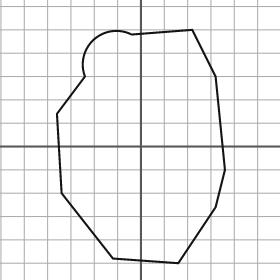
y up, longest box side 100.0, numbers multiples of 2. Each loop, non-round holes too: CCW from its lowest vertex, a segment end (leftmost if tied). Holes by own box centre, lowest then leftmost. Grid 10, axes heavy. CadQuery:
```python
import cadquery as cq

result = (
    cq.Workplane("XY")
    .moveTo(16.0, -50.0)
    .lineTo(32.0, -26.0)
    .lineTo(36.0, -10.0)
    .lineTo(32.0, 30.0)
    .lineTo(22.0, 50.0)
    .lineTo(-4.0, 48.0)
    .threePointArc((-20.0, 46.0), (-24.0, 30.0))
    .lineTo(-36.0, 14.0)
    .lineTo(-34.0, -20.0)
    .lineTo(-12.0, -48.0)
    .close()
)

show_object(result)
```